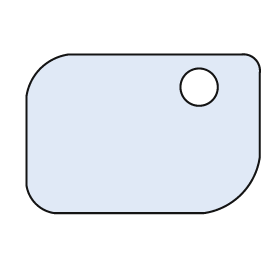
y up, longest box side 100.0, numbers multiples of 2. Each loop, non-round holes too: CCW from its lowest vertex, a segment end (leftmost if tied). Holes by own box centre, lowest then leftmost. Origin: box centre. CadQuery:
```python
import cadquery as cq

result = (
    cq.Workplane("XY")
    .moveTo(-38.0, -34.0)
    .lineTo(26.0, -34.0)
    .threePointArc((42.0, -26.0), (50.0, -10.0))
    .lineTo(50.0, 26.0)
    .threePointArc((48.0, 32.0), (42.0, 34.0))
    .lineTo(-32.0, 34.0)
    .threePointArc((-44.0, 28.0), (-50.0, 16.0))
    .lineTo(-50.0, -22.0)
    .threePointArc((-46.0, -30.0), (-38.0, -34.0))
    .close()
    .moveTo(24.0, 20.0)
    .circle(8.0)
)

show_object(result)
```